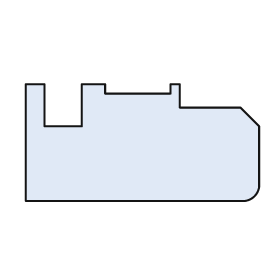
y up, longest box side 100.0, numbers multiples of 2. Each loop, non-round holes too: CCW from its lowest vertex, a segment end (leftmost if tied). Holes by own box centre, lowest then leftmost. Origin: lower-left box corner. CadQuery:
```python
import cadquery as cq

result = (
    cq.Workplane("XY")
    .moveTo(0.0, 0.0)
    .lineTo(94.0, 0.0)
    .threePointArc((98.0, 2.0), (100.0, 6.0))
    .lineTo(100.0, 32.0)
    .lineTo(92.0, 40.0)
    .lineTo(66.0, 40.0)
    .lineTo(66.0, 50.0)
    .lineTo(62.0, 50.0)
    .lineTo(62.0, 46.0)
    .lineTo(34.0, 46.0)
    .lineTo(34.0, 50.0)
    .lineTo(24.0, 50.0)
    .lineTo(24.0, 32.0)
    .lineTo(8.0, 32.0)
    .lineTo(8.0, 50.0)
    .lineTo(0.0, 50.0)
    .close()
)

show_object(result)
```